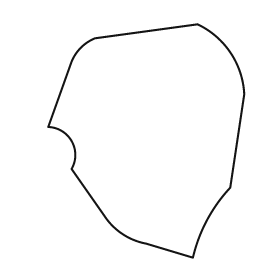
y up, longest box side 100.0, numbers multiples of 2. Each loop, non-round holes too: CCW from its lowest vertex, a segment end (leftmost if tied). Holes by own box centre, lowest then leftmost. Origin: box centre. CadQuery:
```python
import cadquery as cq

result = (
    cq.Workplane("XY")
    .moveTo(20.0, -50.0)
    .threePointArc((26.0, -34.0), (36.0, -20.0))
    .lineTo(42.0, 20.0)
    .threePointArc((36.0, 38.0), (22.0, 50.0))
    .lineTo(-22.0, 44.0)
    .threePointArc((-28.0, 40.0), (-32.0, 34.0))
    .lineTo(-42.0, 6.0)
    .threePointArc((-32.0, 0.0), (-32.0, -12.0))
    .lineTo(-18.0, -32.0)
    .threePointArc((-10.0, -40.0), (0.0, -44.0))
    .close()
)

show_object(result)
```